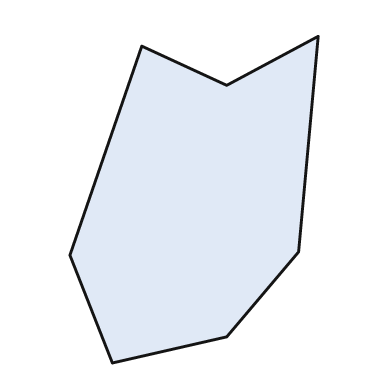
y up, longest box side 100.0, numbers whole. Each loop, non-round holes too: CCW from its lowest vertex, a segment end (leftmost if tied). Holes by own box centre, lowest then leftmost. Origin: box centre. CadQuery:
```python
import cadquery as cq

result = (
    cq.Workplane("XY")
    .moveTo(-25.0, -50.0)
    .lineTo(10.0, -42.0)
    .lineTo(32.0, -16.0)
    .lineTo(38.0, 50.0)
    .lineTo(10.0, 35.0)
    .lineTo(-16.0, 47.0)
    .lineTo(-38.0, -17.0)
    .close()
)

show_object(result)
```